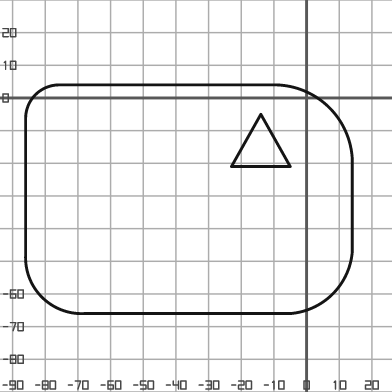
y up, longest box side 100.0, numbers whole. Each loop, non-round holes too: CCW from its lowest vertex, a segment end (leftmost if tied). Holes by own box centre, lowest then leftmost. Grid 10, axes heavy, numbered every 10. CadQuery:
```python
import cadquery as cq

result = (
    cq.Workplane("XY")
    .moveTo(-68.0, -66.0)
    .lineTo(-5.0, -66.0)
    .threePointArc((8.0, -60.0), (14.0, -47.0))
    .lineTo(14.0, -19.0)
    .threePointArc((7.0, -3.0), (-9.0, 4.0))
    .lineTo(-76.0, 4.0)
    .threePointArc((-83.0, 1.0), (-86.0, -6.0))
    .lineTo(-86.0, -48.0)
    .threePointArc((-81.0, -61.0), (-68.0, -66.0))
    .close()
    .moveTo(-23.0, -21.0)
    .lineTo(-5.0, -21.0)
    .lineTo(-14.0, -5.0)
    .close()
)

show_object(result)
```